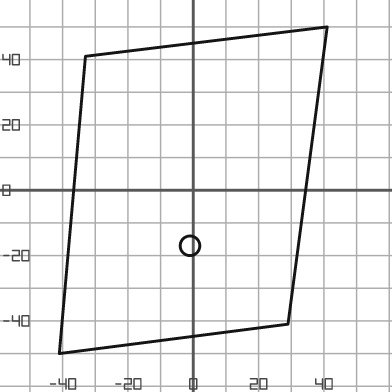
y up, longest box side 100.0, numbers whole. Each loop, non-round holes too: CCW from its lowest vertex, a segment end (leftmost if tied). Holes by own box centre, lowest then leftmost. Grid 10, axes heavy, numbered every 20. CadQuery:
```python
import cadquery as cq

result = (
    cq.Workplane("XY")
    .moveTo(-41.0, -50.0)
    .lineTo(29.0, -41.0)
    .lineTo(41.0, 50.0)
    .lineTo(-33.0, 41.0)
    .close()
    .moveTo(-1.0, -17.0)
    .circle(3.0)
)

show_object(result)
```